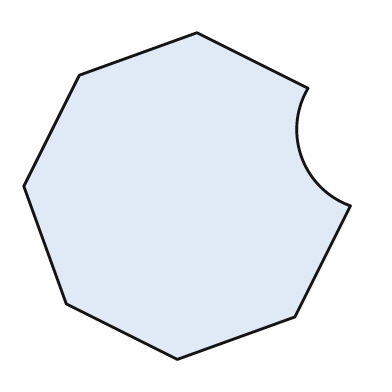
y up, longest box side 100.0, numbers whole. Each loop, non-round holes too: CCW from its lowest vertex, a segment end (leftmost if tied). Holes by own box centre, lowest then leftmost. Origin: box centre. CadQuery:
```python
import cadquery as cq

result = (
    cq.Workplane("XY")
    .moveTo(-3.0, -50.0)
    .lineTo(33.0, -37.0)
    .lineTo(50.0, -3.0)
    .threePointArc((35.0, 12.0), (37.0, 33.0))
    .lineTo(3.0, 50.0)
    .lineTo(-33.0, 37.0)
    .lineTo(-50.0, 3.0)
    .lineTo(-37.0, -33.0)
    .close()
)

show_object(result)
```